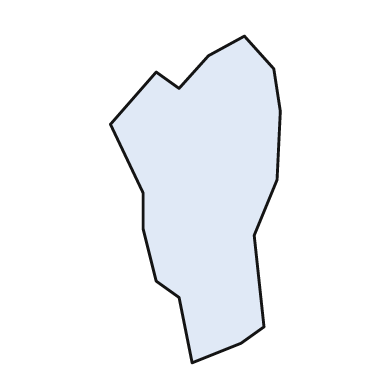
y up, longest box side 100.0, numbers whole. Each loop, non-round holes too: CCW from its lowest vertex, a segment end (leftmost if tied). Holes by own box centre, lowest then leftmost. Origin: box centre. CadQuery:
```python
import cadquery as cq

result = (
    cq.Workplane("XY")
    .moveTo(-1.0, -50.0)
    .lineTo(14.0, -44.0)
    .lineTo(21.0, -39.0)
    .lineTo(18.0, -11.0)
    .lineTo(25.0, 6.0)
    .lineTo(26.0, 27.0)
    .lineTo(24.0, 40.0)
    .lineTo(15.0, 50.0)
    .lineTo(4.0, 44.0)
    .lineTo(-5.0, 34.0)
    .lineTo(-12.0, 39.0)
    .lineTo(-26.0, 23.0)
    .lineTo(-16.0, 2.0)
    .lineTo(-16.0, -9.0)
    .lineTo(-12.0, -25.0)
    .lineTo(-5.0, -30.0)
    .close()
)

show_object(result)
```